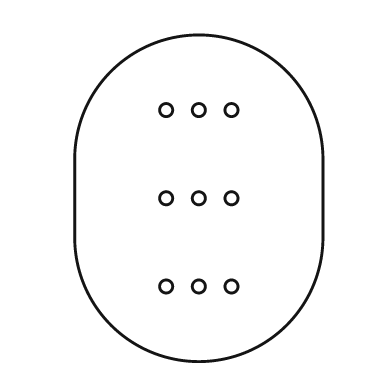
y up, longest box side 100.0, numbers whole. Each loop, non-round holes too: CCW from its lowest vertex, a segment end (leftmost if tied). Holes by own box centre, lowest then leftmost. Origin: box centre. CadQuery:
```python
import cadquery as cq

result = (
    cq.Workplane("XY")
    .moveTo(-38.0, -12.0)
    .threePointArc((0.0, -50.0), (38.0, -12.0))
    .lineTo(38.0, 12.0)
    .threePointArc((0.0, 50.0), (-38.0, 12.0))
    .close()
    .moveTo(-10.0, -27.0)
    .circle(2.0)
    .moveTo(0.0, -27.0)
    .circle(2.0)
    .moveTo(10.0, -27.0)
    .circle(2.0)
    .moveTo(-10.0, 0.0)
    .circle(2.0)
    .moveTo(0.0, 0.0)
    .circle(2.0)
    .moveTo(10.0, 0.0)
    .circle(2.0)
    .moveTo(-10.0, 27.0)
    .circle(2.0)
    .moveTo(0.0, 27.0)
    .circle(2.0)
    .moveTo(10.0, 27.0)
    .circle(2.0)
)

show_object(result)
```